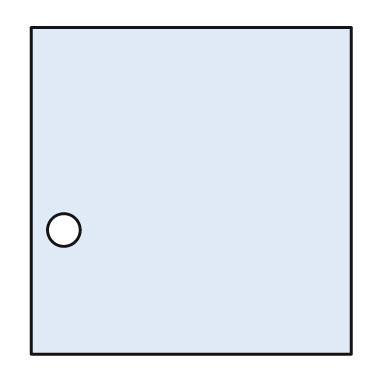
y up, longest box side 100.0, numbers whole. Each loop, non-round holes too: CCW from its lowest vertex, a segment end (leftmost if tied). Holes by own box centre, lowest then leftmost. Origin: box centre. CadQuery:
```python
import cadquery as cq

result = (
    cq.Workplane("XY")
    .moveTo(-49.0, -50.0)
    .lineTo(49.0, -50.0)
    .lineTo(49.0, 50.0)
    .lineTo(-49.0, 50.0)
    .close()
    .moveTo(-39.0, -12.0)
    .circle(5.0)
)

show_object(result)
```